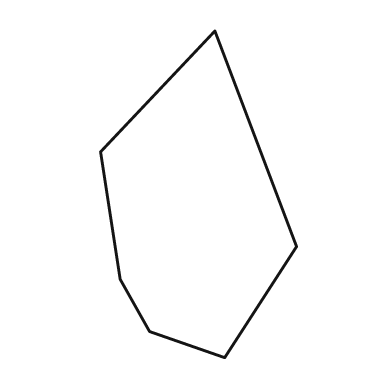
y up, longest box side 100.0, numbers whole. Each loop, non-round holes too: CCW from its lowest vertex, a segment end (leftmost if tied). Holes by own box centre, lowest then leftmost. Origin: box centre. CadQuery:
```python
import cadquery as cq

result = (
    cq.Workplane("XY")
    .moveTo(8.0, -50.0)
    .lineTo(30.0, -16.0)
    .lineTo(5.0, 50.0)
    .lineTo(-30.0, 13.0)
    .lineTo(-24.0, -26.0)
    .lineTo(-15.0, -42.0)
    .close()
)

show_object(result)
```